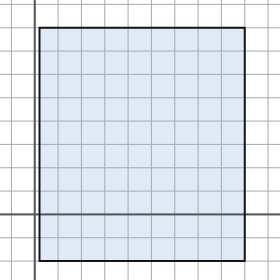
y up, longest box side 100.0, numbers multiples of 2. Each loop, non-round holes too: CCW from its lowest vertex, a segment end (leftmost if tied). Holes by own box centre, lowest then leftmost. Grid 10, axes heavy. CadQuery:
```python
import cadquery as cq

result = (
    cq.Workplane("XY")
    .moveTo(2.0, -20.0)
    .lineTo(90.0, -20.0)
    .lineTo(90.0, 80.0)
    .lineTo(2.0, 80.0)
    .close()
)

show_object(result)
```